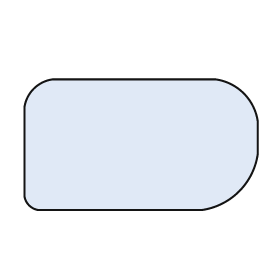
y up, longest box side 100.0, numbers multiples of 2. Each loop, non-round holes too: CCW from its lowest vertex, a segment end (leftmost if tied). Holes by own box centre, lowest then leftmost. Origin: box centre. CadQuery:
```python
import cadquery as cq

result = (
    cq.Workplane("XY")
    .moveTo(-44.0, -28.0)
    .lineTo(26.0, -28.0)
    .threePointArc((42.0, -20.0), (50.0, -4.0))
    .lineTo(50.0, 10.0)
    .threePointArc((44.0, 22.0), (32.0, 28.0))
    .lineTo(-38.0, 28.0)
    .threePointArc((-46.0, 24.0), (-50.0, 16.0))
    .lineTo(-50.0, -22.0)
    .threePointArc((-48.0, -26.0), (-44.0, -28.0))
    .close()
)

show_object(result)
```